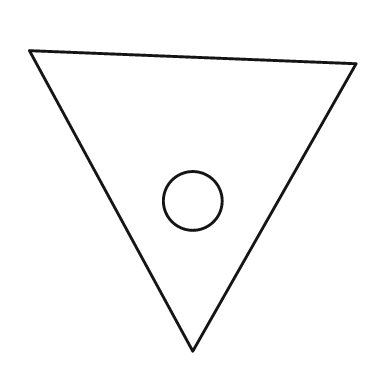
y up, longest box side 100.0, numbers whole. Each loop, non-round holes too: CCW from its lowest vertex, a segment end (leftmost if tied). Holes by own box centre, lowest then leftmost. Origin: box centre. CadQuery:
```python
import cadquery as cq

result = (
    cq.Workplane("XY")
    .moveTo(0.0, -46.0)
    .lineTo(50.0, 42.0)
    .lineTo(-50.0, 46.0)
    .close()
    .moveTo(0.0, 0.0)
    .circle(9.0)
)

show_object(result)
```